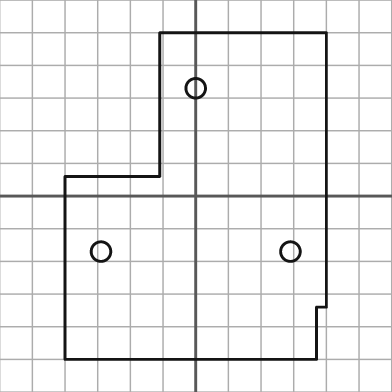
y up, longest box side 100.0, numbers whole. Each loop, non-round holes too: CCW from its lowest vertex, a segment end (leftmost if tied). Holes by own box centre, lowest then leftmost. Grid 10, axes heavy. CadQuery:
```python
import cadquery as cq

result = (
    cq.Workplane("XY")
    .moveTo(-40.0, -50.0)
    .lineTo(37.0, -50.0)
    .lineTo(37.0, -34.0)
    .lineTo(40.0, -34.0)
    .lineTo(40.0, 50.0)
    .lineTo(-11.0, 50.0)
    .lineTo(-11.0, 6.0)
    .lineTo(-40.0, 6.0)
    .close()
    .moveTo(-29.0, -17.0)
    .circle(3.0)
    .moveTo(29.0, -17.0)
    .circle(3.0)
    .moveTo(0.0, 33.0)
    .circle(3.0)
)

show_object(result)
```